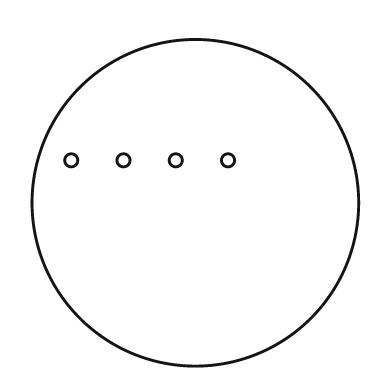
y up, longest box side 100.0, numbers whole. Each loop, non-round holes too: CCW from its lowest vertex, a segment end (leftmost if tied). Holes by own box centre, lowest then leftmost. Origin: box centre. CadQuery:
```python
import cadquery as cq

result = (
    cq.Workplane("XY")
    .moveTo(0.0, 0.0)
    .circle(50.0)
    .moveTo(-38.0, 13.0)
    .circle(2.0)
    .moveTo(-22.0, 13.0)
    .circle(2.0)
    .moveTo(-6.0, 13.0)
    .circle(2.0)
    .moveTo(10.0, 13.0)
    .circle(2.0)
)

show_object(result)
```